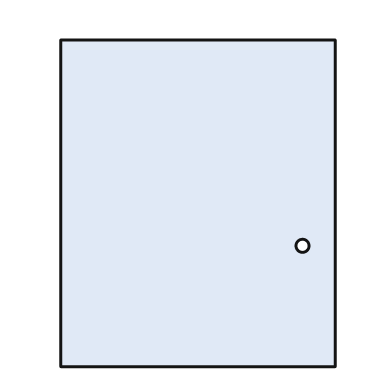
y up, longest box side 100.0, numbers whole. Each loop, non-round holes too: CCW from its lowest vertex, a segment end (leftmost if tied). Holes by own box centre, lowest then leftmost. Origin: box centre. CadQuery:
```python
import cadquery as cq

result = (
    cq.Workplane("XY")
    .moveTo(-42.0, -50.0)
    .lineTo(42.0, -50.0)
    .lineTo(42.0, 50.0)
    .lineTo(-42.0, 50.0)
    .close()
    .moveTo(32.0, -13.0)
    .circle(2.0)
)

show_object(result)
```